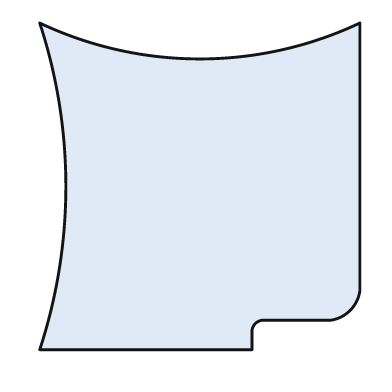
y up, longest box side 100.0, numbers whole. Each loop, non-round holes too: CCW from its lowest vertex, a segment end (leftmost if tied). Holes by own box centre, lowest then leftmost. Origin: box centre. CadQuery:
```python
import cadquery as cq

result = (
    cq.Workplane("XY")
    .moveTo(-49.0, -50.0)
    .lineTo(16.0, -50.0)
    .lineTo(16.0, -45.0)
    .threePointArc((17.0, -42.0), (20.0, -41.0))
    .lineTo(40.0, -41.0)
    .threePointArc((46.0, -38.0), (49.0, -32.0))
    .lineTo(49.0, 50.0)
    .threePointArc((0.0, 39.0), (-49.0, 50.0))
    .threePointArc((-41.0, 0.0), (-49.0, -50.0))
    .close()
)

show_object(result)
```